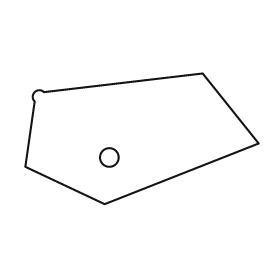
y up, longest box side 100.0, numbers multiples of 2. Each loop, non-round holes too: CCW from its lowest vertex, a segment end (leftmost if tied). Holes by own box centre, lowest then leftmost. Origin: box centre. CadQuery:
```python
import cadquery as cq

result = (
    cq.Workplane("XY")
    .moveTo(-16.0, -28.0)
    .lineTo(50.0, -2.0)
    .lineTo(26.0, 28.0)
    .lineTo(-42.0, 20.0)
    .threePointArc((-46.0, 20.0), (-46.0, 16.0))
    .lineTo(-50.0, -12.0)
    .close()
    .moveTo(-14.0, -8.0)
    .circle(4.0)
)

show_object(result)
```